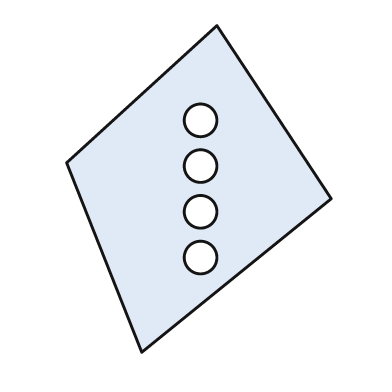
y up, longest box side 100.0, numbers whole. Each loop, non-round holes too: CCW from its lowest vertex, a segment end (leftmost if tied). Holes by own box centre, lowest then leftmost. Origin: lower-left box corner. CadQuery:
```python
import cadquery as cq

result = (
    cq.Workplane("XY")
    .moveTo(23.0, 0.0)
    .lineTo(81.0, 47.0)
    .lineTo(46.0, 100.0)
    .lineTo(0.0, 58.0)
    .close()
    .moveTo(41.0, 29.0)
    .circle(5.0)
    .moveTo(41.0, 43.0)
    .circle(5.0)
    .moveTo(41.0, 57.0)
    .circle(5.0)
    .moveTo(41.0, 71.0)
    .circle(5.0)
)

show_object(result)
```